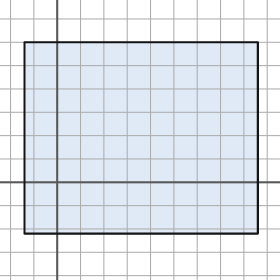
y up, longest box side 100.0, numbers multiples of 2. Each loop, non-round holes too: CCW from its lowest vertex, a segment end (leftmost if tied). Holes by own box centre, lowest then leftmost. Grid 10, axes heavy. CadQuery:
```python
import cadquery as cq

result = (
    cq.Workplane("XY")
    .moveTo(-14.0, -22.0)
    .lineTo(86.0, -22.0)
    .lineTo(86.0, 60.0)
    .lineTo(-14.0, 60.0)
    .close()
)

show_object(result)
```